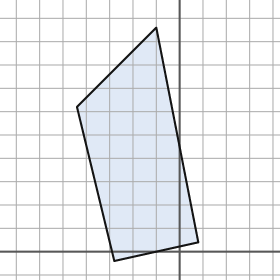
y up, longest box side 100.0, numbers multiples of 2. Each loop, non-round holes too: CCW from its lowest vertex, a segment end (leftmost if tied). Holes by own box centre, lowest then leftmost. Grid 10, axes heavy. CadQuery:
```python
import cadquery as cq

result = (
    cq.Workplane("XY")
    .moveTo(-28.0, -4.0)
    .lineTo(8.0, 4.0)
    .lineTo(-10.0, 96.0)
    .lineTo(-44.0, 62.0)
    .close()
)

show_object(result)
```